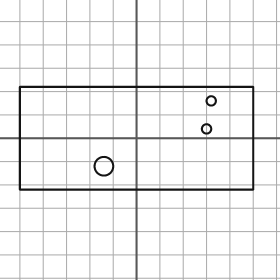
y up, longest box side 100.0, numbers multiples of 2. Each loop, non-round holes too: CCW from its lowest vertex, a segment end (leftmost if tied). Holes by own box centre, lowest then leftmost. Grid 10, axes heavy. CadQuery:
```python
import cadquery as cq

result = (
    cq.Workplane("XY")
    .moveTo(-50.0, -22.0)
    .lineTo(50.0, -22.0)
    .lineTo(50.0, 22.0)
    .lineTo(-50.0, 22.0)
    .close()
    .moveTo(-14.0, -12.0)
    .circle(4.0)
    .moveTo(30.0, 4.0)
    .circle(2.0)
    .moveTo(32.0, 16.0)
    .circle(2.0)
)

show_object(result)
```